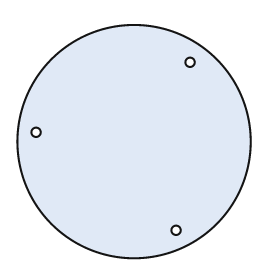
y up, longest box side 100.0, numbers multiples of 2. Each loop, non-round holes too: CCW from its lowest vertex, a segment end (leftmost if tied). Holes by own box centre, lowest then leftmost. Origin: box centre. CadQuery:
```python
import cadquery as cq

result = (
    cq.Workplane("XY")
    .moveTo(0.0, 0.0)
    .circle(50.0)
    .moveTo(18.0, -38.0)
    .circle(2.0)
    .moveTo(-42.0, 4.0)
    .circle(2.0)
    .moveTo(24.0, 34.0)
    .circle(2.0)
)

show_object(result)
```